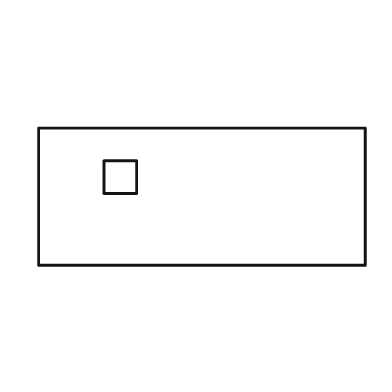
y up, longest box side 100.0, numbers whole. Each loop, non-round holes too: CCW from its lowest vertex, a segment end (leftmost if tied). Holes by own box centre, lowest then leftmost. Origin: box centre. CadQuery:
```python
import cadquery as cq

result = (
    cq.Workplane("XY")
    .moveTo(-50.0, -21.0)
    .lineTo(50.0, -21.0)
    .lineTo(50.0, 21.0)
    .lineTo(-50.0, 21.0)
    .close()
    .moveTo(-30.0, 1.0)
    .lineTo(-20.0, 1.0)
    .lineTo(-20.0, 11.0)
    .lineTo(-30.0, 11.0)
    .close()
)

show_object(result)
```